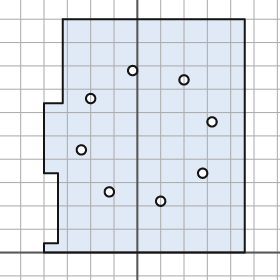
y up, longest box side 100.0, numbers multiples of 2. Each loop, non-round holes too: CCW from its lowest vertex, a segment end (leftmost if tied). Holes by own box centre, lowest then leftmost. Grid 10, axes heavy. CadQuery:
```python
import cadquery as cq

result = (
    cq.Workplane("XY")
    .moveTo(-40.0, 0.0)
    .lineTo(46.0, 0.0)
    .lineTo(46.0, 100.0)
    .lineTo(-32.0, 100.0)
    .lineTo(-32.0, 64.0)
    .lineTo(-40.0, 64.0)
    .lineTo(-40.0, 34.0)
    .lineTo(-34.0, 34.0)
    .lineTo(-34.0, 4.0)
    .lineTo(-40.0, 4.0)
    .close()
    .moveTo(10.0, 22.0)
    .circle(2.0)
    .moveTo(-12.0, 26.0)
    .circle(2.0)
    .moveTo(28.0, 34.0)
    .circle(2.0)
    .moveTo(-24.0, 44.0)
    .circle(2.0)
    .moveTo(32.0, 56.0)
    .circle(2.0)
    .moveTo(-20.0, 66.0)
    .circle(2.0)
    .moveTo(20.0, 74.0)
    .circle(2.0)
    .moveTo(-2.0, 78.0)
    .circle(2.0)
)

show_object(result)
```